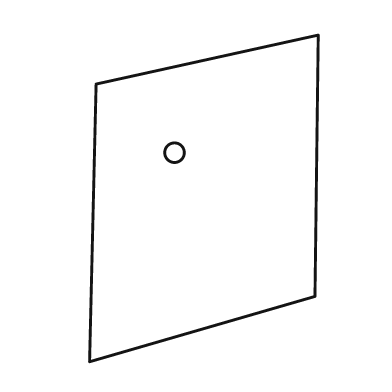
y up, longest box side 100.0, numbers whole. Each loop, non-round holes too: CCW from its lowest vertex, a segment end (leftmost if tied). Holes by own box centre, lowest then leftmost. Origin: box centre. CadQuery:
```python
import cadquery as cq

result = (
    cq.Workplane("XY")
    .moveTo(-35.0, -50.0)
    .lineTo(34.0, -30.0)
    .lineTo(35.0, 50.0)
    .lineTo(-33.0, 35.0)
    .close()
    .moveTo(-9.0, 14.0)
    .circle(3.0)
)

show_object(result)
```